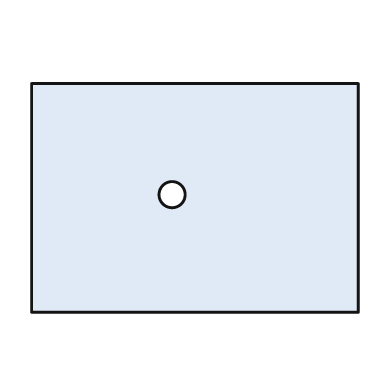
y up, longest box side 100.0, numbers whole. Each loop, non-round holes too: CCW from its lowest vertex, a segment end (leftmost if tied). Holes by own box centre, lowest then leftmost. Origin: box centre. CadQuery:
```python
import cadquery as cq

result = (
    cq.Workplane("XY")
    .moveTo(-50.0, -35.0)
    .lineTo(50.0, -35.0)
    .lineTo(50.0, 35.0)
    .lineTo(-50.0, 35.0)
    .close()
    .moveTo(-7.0, 1.0)
    .circle(4.0)
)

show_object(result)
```